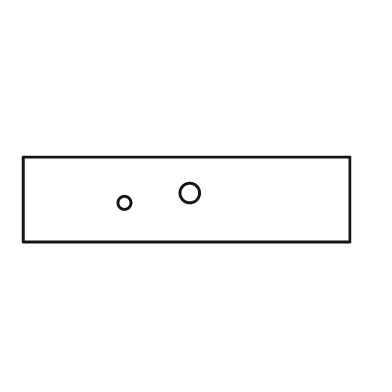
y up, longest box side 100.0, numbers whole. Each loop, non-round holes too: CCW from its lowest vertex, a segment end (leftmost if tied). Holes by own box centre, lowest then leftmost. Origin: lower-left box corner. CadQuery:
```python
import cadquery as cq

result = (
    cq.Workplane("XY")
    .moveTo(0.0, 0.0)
    .lineTo(100.0, 0.0)
    .lineTo(100.0, 26.0)
    .lineTo(0.0, 26.0)
    .close()
    .moveTo(31.0, 12.0)
    .circle(2.0)
    .moveTo(51.0, 15.0)
    .circle(3.0)
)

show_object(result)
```